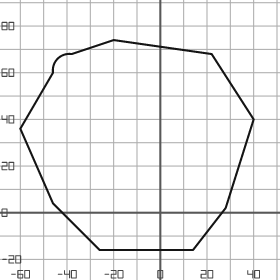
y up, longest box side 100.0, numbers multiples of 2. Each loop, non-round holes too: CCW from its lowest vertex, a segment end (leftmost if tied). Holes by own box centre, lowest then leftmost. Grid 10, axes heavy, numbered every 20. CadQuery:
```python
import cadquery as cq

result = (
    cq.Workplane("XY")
    .moveTo(-26.0, -16.0)
    .lineTo(14.0, -16.0)
    .lineTo(28.0, 2.0)
    .lineTo(40.0, 40.0)
    .lineTo(22.0, 68.0)
    .lineTo(-20.0, 74.0)
    .lineTo(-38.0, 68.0)
    .threePointArc((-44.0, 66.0), (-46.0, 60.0))
    .lineTo(-60.0, 36.0)
    .lineTo(-46.0, 4.0)
    .close()
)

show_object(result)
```